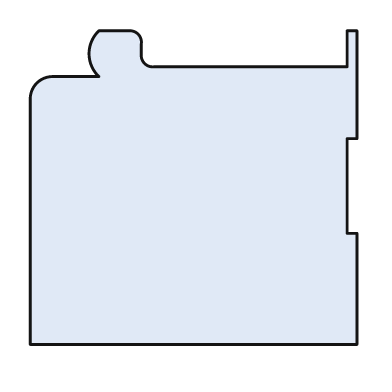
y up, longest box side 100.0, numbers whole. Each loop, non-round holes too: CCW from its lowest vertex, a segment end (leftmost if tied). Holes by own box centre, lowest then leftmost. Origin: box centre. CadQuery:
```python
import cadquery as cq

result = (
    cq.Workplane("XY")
    .moveTo(-50.0, -48.0)
    .lineTo(50.0, -48.0)
    .lineTo(50.0, -14.0)
    .lineTo(47.0, -14.0)
    .lineTo(47.0, 15.0)
    .lineTo(50.0, 15.0)
    .lineTo(50.0, 48.0)
    .lineTo(47.0, 48.0)
    .lineTo(47.0, 37.0)
    .lineTo(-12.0, 37.0)
    .threePointArc((-15.0, 38.0), (-16.0, 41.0))
    .lineTo(-16.0, 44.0)
    .threePointArc((-17.0, 47.0), (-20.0, 48.0))
    .lineTo(-29.0, 48.0)
    .threePointArc((-32.0, 41.0), (-29.0, 34.0))
    .lineTo(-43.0, 34.0)
    .threePointArc((-48.0, 32.0), (-50.0, 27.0))
    .close()
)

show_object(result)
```